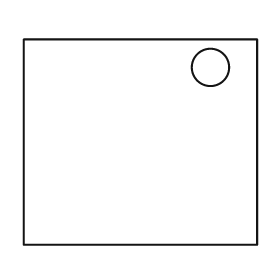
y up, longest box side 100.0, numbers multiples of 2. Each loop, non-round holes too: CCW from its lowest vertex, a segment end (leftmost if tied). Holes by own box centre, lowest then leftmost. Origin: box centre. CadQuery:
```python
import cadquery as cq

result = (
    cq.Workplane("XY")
    .moveTo(-50.0, -44.0)
    .lineTo(50.0, -44.0)
    .lineTo(50.0, 44.0)
    .lineTo(-50.0, 44.0)
    .close()
    .moveTo(30.0, 32.0)
    .circle(8.0)
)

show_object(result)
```